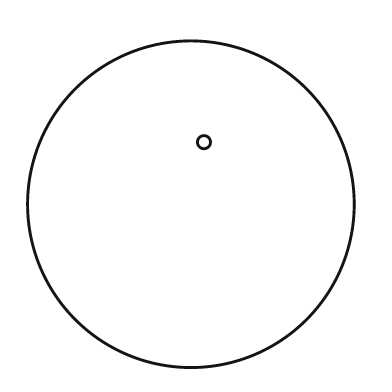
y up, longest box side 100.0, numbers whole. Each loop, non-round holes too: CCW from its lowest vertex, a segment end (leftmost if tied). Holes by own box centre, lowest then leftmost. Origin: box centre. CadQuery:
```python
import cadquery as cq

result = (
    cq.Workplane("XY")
    .moveTo(0.0, 0.0)
    .circle(50.0)
    .moveTo(4.0, 19.0)
    .circle(2.0)
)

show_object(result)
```